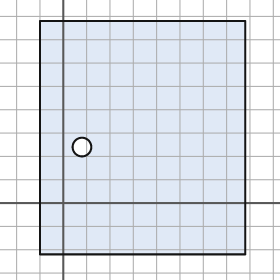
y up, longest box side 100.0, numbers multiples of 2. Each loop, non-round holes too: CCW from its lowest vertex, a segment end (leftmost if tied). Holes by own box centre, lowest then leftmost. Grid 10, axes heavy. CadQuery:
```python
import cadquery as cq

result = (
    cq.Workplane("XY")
    .moveTo(-10.0, -22.0)
    .lineTo(78.0, -22.0)
    .lineTo(78.0, 78.0)
    .lineTo(-10.0, 78.0)
    .close()
    .moveTo(8.0, 24.0)
    .circle(4.0)
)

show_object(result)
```